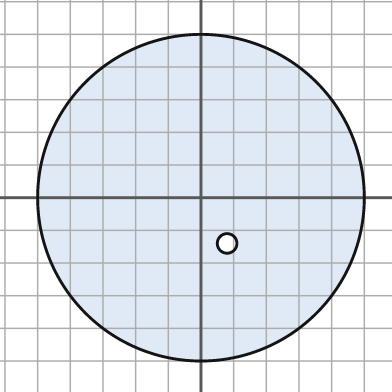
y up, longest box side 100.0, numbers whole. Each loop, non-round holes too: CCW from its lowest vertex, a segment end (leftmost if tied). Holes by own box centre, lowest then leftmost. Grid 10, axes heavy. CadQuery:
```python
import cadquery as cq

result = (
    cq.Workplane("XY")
    .moveTo(0.0, 0.0)
    .circle(50.0)
    .moveTo(8.0, -14.0)
    .circle(3.0)
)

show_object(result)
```